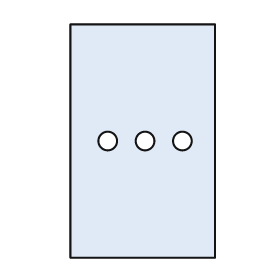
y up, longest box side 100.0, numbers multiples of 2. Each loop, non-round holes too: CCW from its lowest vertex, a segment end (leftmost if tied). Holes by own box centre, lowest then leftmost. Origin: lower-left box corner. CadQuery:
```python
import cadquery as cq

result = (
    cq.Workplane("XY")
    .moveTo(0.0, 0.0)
    .lineTo(62.0, 0.0)
    .lineTo(62.0, 100.0)
    .lineTo(0.0, 100.0)
    .close()
    .moveTo(16.0, 50.0)
    .circle(4.0)
    .moveTo(32.0, 50.0)
    .circle(4.0)
    .moveTo(48.0, 50.0)
    .circle(4.0)
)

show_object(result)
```